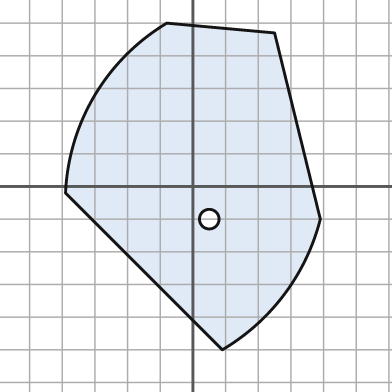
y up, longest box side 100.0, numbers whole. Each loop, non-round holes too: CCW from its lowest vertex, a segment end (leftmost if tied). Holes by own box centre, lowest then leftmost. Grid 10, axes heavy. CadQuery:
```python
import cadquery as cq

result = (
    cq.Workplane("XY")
    .moveTo(9.0, -50.0)
    .threePointArc((28.0, -33.0), (39.0, -10.0))
    .lineTo(25.0, 47.0)
    .lineTo(-8.0, 50.0)
    .threePointArc((-30.0, 28.0), (-39.0, -2.0))
    .close()
    .moveTo(5.0, -10.0)
    .circle(3.0)
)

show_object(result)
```